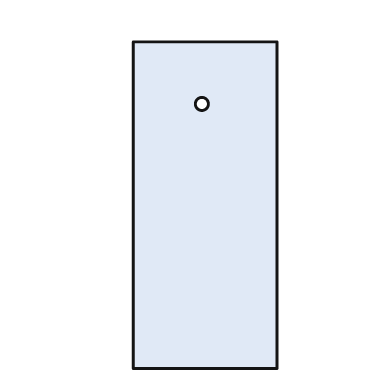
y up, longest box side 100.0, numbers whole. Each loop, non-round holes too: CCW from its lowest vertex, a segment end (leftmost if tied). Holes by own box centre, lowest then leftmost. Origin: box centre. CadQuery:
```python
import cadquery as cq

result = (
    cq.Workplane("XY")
    .moveTo(-22.0, -50.0)
    .lineTo(22.0, -50.0)
    .lineTo(22.0, 50.0)
    .lineTo(-22.0, 50.0)
    .close()
    .moveTo(-1.0, 31.0)
    .circle(2.0)
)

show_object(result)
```